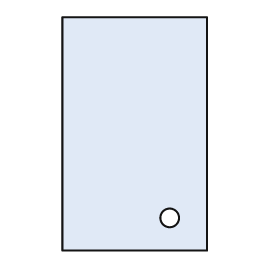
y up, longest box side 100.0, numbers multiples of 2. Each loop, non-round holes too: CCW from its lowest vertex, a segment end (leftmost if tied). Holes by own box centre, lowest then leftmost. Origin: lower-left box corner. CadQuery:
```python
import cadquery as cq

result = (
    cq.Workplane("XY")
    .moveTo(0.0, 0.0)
    .lineTo(62.0, 0.0)
    .lineTo(62.0, 100.0)
    .lineTo(0.0, 100.0)
    .close()
    .moveTo(46.0, 14.0)
    .circle(4.0)
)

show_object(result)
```